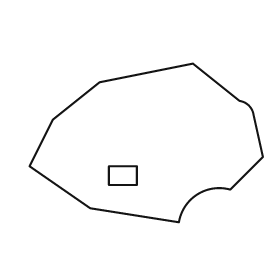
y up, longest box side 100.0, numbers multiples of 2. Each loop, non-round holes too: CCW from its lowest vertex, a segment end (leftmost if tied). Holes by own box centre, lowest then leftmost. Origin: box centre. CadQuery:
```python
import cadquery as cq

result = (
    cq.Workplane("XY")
    .moveTo(14.0, -34.0)
    .threePointArc((22.0, -22.0), (36.0, -20.0))
    .lineTo(50.0, -6.0)
    .lineTo(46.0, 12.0)
    .threePointArc((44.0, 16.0), (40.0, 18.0))
    .lineTo(20.0, 34.0)
    .lineTo(-20.0, 26.0)
    .lineTo(-40.0, 10.0)
    .lineTo(-50.0, -10.0)
    .lineTo(-24.0, -28.0)
    .close()
    .moveTo(-16.0, -18.0)
    .lineTo(-4.0, -18.0)
    .lineTo(-4.0, -10.0)
    .lineTo(-16.0, -10.0)
    .close()
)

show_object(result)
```